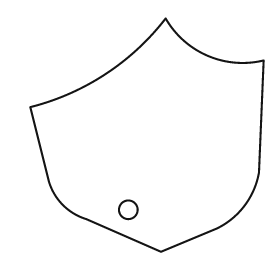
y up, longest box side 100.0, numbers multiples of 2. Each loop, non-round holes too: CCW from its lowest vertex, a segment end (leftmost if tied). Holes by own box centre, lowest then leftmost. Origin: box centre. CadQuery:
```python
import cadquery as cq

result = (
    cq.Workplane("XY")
    .moveTo(6.0, -50.0)
    .lineTo(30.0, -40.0)
    .threePointArc((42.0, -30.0), (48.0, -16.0))
    .lineTo(50.0, 32.0)
    .threePointArc((26.0, 34.0), (8.0, 50.0))
    .threePointArc((-18.0, 26.0), (-50.0, 12.0))
    .lineTo(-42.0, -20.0)
    .threePointArc((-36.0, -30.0), (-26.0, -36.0))
    .close()
    .moveTo(-8.0, -32.0)
    .circle(4.0)
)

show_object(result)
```